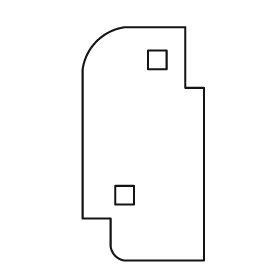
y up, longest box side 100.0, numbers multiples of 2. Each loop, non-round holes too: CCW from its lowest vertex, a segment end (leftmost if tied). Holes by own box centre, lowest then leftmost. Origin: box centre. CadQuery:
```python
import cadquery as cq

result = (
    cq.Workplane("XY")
    .moveTo(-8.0, -50.0)
    .lineTo(26.0, -50.0)
    .lineTo(26.0, 24.0)
    .lineTo(18.0, 24.0)
    .lineTo(18.0, 50.0)
    .lineTo(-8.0, 50.0)
    .threePointArc((-20.0, 44.0), (-26.0, 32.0))
    .lineTo(-26.0, -32.0)
    .lineTo(-14.0, -32.0)
    .lineTo(-14.0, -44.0)
    .threePointArc((-12.0, -48.0), (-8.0, -50.0))
    .close()
    .moveTo(-12.0, -26.0)
    .lineTo(-4.0, -26.0)
    .lineTo(-4.0, -18.0)
    .lineTo(-12.0, -18.0)
    .close()
    .moveTo(2.0, 32.0)
    .lineTo(10.0, 32.0)
    .lineTo(10.0, 40.0)
    .lineTo(2.0, 40.0)
    .close()
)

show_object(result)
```